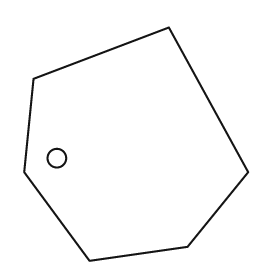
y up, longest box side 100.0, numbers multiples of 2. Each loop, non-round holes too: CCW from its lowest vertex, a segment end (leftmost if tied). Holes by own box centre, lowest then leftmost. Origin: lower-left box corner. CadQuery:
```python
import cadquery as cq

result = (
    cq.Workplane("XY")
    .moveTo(28.0, 0.0)
    .lineTo(70.0, 6.0)
    .lineTo(96.0, 38.0)
    .lineTo(62.0, 100.0)
    .lineTo(4.0, 78.0)
    .lineTo(0.0, 38.0)
    .close()
    .moveTo(14.0, 44.0)
    .circle(4.0)
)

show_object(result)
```